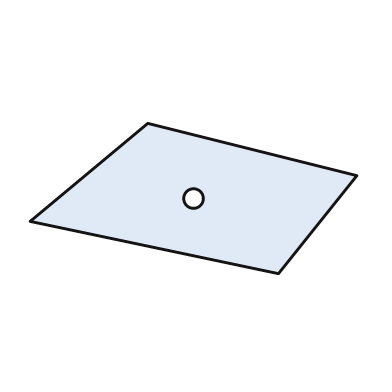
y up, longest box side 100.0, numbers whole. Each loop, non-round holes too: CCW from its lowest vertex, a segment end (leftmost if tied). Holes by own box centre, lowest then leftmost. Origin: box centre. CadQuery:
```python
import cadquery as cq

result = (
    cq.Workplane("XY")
    .moveTo(26.0, -23.0)
    .lineTo(50.0, 7.0)
    .lineTo(-14.0, 23.0)
    .lineTo(-50.0, -7.0)
    .close()
    .moveTo(0.0, 0.0)
    .circle(3.0)
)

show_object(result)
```